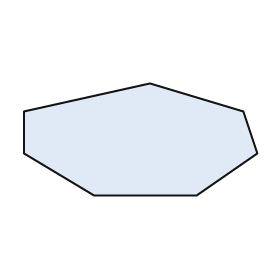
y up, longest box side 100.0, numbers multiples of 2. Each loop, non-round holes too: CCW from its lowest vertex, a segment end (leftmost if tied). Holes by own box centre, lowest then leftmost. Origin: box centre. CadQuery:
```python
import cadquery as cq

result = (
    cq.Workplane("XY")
    .moveTo(-20.0, -24.0)
    .lineTo(24.0, -24.0)
    .lineTo(50.0, -6.0)
    .lineTo(44.0, 12.0)
    .lineTo(4.0, 24.0)
    .lineTo(-50.0, 12.0)
    .lineTo(-50.0, -6.0)
    .close()
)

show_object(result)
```